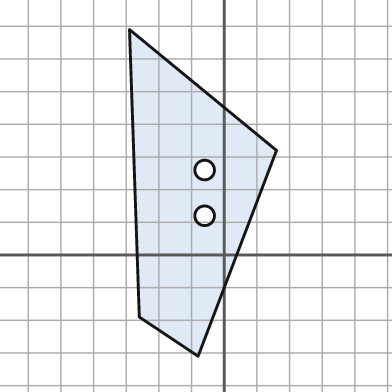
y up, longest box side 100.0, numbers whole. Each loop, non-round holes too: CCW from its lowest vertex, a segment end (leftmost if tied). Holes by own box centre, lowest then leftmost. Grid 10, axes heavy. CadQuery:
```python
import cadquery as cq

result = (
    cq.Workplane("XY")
    .moveTo(-8.0, -31.0)
    .lineTo(16.0, 32.0)
    .lineTo(-29.0, 69.0)
    .lineTo(-26.0, -19.0)
    .close()
    .moveTo(-6.0, 12.0)
    .circle(3.0)
    .moveTo(-6.0, 26.0)
    .circle(3.0)
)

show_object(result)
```